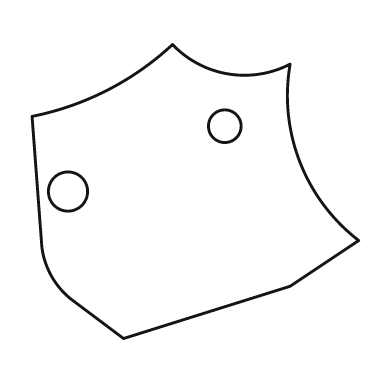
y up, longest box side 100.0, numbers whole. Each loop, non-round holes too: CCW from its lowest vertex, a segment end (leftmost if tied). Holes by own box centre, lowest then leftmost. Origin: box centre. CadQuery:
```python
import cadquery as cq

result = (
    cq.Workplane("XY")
    .moveTo(-22.0, -45.0)
    .lineTo(29.0, -29.0)
    .lineTo(50.0, -15.0)
    .threePointArc((32.0, 9.0), (29.0, 39.0))
    .threePointArc((10.0, 36.0), (-7.0, 45.0))
    .threePointArc((-27.0, 31.0), (-50.0, 23.0))
    .lineTo(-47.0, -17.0)
    .threePointArc((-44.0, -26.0), (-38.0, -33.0))
    .close()
    .moveTo(-39.0, 0.0)
    .circle(6.0)
    .moveTo(9.0, 20.0)
    .circle(5.0)
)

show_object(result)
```